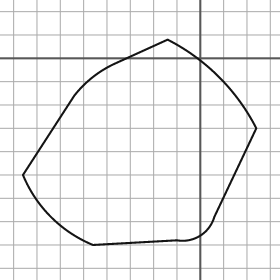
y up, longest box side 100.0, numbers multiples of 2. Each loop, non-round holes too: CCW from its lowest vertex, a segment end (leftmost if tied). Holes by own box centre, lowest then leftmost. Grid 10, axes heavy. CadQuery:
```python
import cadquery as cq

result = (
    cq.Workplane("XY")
    .moveTo(-46.0, -80.0)
    .lineTo(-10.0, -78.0)
    .threePointArc((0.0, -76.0), (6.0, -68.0))
    .lineTo(24.0, -30.0)
    .threePointArc((8.0, -8.0), (-14.0, 8.0))
    .lineTo(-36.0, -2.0)
    .threePointArc((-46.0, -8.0), (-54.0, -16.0))
    .lineTo(-76.0, -50.0)
    .threePointArc((-64.0, -68.0), (-46.0, -80.0))
    .close()
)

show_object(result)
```